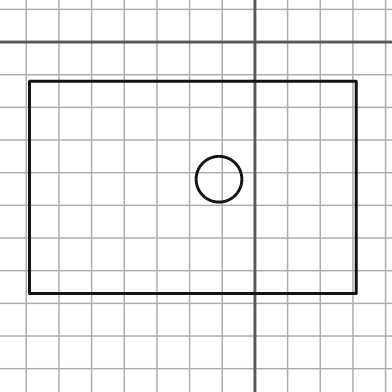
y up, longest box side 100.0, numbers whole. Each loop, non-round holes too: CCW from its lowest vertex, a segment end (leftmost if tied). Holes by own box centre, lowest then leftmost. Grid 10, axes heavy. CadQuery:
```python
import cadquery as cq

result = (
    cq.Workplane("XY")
    .moveTo(-69.0, -77.0)
    .lineTo(31.0, -77.0)
    .lineTo(31.0, -12.0)
    .lineTo(-69.0, -12.0)
    .close()
    .moveTo(-11.0, -42.0)
    .circle(7.0)
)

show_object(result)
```